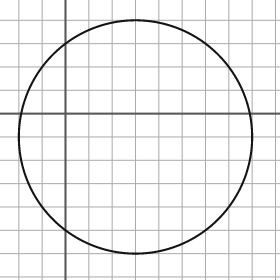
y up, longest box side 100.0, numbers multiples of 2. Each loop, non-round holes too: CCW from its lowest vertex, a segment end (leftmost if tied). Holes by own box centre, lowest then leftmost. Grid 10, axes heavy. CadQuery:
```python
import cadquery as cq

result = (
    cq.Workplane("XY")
    .moveTo(30.0, -10.0)
    .circle(50.0)
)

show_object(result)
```